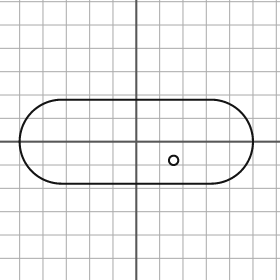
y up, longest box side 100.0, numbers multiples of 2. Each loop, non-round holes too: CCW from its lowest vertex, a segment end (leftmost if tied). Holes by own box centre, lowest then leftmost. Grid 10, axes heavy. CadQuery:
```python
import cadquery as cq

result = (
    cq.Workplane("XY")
    .moveTo(-32.0, -18.0)
    .lineTo(32.0, -18.0)
    .threePointArc((50.0, 0.0), (32.0, 18.0))
    .lineTo(-32.0, 18.0)
    .threePointArc((-50.0, 0.0), (-32.0, -18.0))
    .close()
    .moveTo(16.0, -8.0)
    .circle(2.0)
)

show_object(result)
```